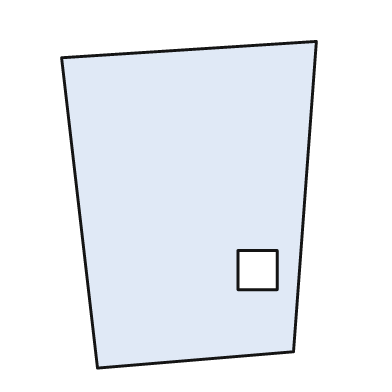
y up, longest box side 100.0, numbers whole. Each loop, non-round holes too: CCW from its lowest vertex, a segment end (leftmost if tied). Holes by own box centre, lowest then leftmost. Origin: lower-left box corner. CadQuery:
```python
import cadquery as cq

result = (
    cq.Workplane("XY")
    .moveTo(11.0, 0.0)
    .lineTo(71.0, 5.0)
    .lineTo(78.0, 100.0)
    .lineTo(0.0, 95.0)
    .close()
    .moveTo(54.0, 24.0)
    .lineTo(66.0, 24.0)
    .lineTo(66.0, 36.0)
    .lineTo(54.0, 36.0)
    .close()
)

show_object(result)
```